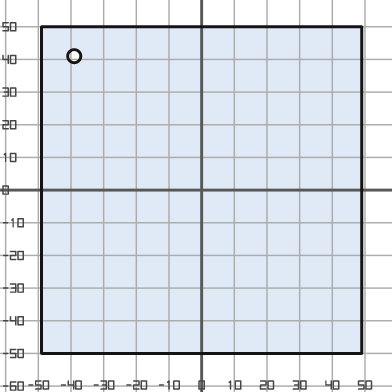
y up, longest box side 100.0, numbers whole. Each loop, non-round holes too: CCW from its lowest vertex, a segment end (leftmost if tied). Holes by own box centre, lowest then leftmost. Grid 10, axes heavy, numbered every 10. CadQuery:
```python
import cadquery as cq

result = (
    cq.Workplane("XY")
    .moveTo(-49.0, -50.0)
    .lineTo(49.0, -50.0)
    .lineTo(49.0, 50.0)
    .lineTo(-49.0, 50.0)
    .close()
    .moveTo(-39.0, 41.0)
    .circle(2.0)
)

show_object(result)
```